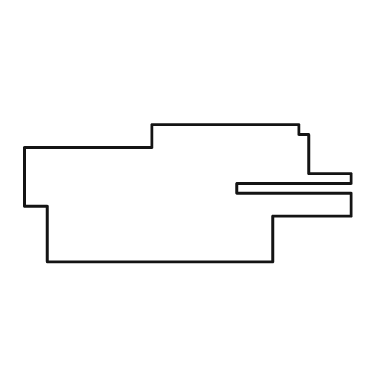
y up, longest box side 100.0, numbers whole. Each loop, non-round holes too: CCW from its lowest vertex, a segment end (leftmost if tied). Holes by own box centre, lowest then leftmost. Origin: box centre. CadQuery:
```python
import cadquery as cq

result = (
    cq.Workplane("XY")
    .moveTo(-43.0, -21.0)
    .lineTo(26.0, -21.0)
    .lineTo(26.0, -7.0)
    .lineTo(50.0, -7.0)
    .lineTo(50.0, 0.0)
    .lineTo(15.0, 0.0)
    .lineTo(15.0, 3.0)
    .lineTo(50.0, 3.0)
    .lineTo(50.0, 6.0)
    .lineTo(37.0, 6.0)
    .lineTo(37.0, 18.0)
    .lineTo(34.0, 18.0)
    .lineTo(34.0, 21.0)
    .lineTo(-11.0, 21.0)
    .lineTo(-11.0, 14.0)
    .lineTo(-50.0, 14.0)
    .lineTo(-50.0, -4.0)
    .lineTo(-43.0, -4.0)
    .close()
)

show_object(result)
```